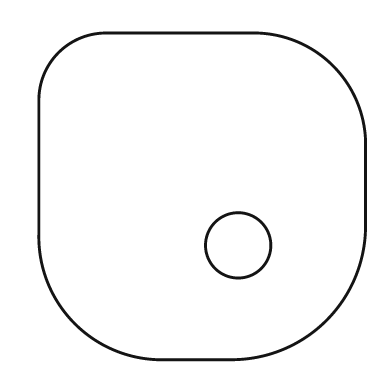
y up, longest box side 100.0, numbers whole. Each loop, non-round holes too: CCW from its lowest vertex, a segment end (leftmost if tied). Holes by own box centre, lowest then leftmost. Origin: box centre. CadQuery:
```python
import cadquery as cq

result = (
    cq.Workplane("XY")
    .moveTo(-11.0, -50.0)
    .lineTo(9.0, -50.0)
    .threePointArc((38.0, -38.0), (50.0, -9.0))
    .lineTo(50.0, 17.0)
    .threePointArc((40.0, 40.0), (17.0, 50.0))
    .lineTo(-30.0, 50.0)
    .threePointArc((-44.0, 44.0), (-50.0, 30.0))
    .lineTo(-50.0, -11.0)
    .threePointArc((-39.0, -39.0), (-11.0, -50.0))
    .close()
    .moveTo(11.0, -15.0)
    .circle(10.0)
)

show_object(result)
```